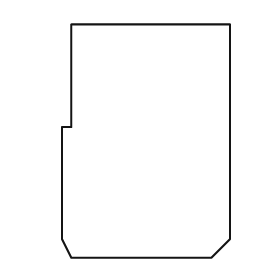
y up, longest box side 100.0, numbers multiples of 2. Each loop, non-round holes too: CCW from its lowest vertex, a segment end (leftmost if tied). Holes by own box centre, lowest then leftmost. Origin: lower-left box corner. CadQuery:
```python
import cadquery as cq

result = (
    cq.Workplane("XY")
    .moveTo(4.0, 0.0)
    .lineTo(64.0, 0.0)
    .lineTo(72.0, 8.0)
    .lineTo(72.0, 100.0)
    .lineTo(4.0, 100.0)
    .lineTo(4.0, 56.0)
    .lineTo(0.0, 56.0)
    .lineTo(0.0, 8.0)
    .close()
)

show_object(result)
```